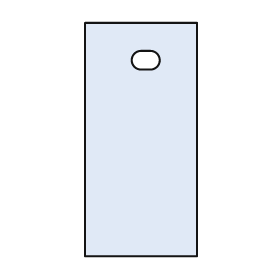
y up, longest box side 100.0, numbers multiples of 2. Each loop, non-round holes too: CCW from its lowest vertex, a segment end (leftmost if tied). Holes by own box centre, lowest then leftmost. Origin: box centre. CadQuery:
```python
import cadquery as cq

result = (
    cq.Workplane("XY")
    .moveTo(-24.0, -50.0)
    .lineTo(24.0, -50.0)
    .lineTo(24.0, 50.0)
    .lineTo(-24.0, 50.0)
    .close()
    .moveTo(0.0, 30.0)
    .lineTo(4.0, 30.0)
    .threePointArc((8.0, 34.0), (4.0, 38.0))
    .lineTo(0.0, 38.0)
    .threePointArc((-4.0, 34.0), (0.0, 30.0))
    .close()
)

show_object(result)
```